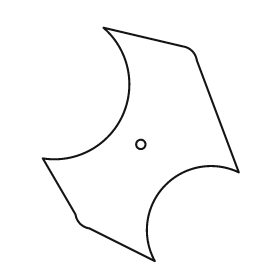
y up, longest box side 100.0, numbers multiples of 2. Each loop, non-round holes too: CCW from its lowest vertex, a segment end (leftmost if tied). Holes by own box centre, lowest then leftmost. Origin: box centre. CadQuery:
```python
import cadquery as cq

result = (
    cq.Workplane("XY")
    .moveTo(6.0, -50.0)
    .threePointArc((10.0, -18.0), (42.0, -12.0))
    .lineTo(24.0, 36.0)
    .threePointArc((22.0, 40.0), (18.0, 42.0))
    .lineTo(-16.0, 50.0)
    .threePointArc((-8.0, 12.0), (-42.0, -6.0))
    .lineTo(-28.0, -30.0)
    .threePointArc((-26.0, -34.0), (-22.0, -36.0))
    .close()
    .moveTo(0.0, 0.0)
    .circle(2.0)
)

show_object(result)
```